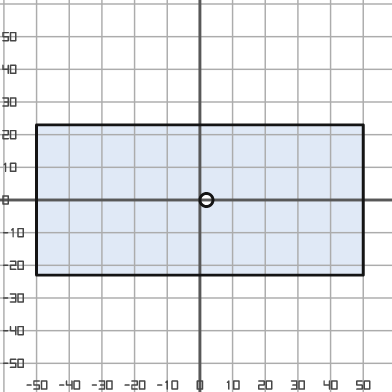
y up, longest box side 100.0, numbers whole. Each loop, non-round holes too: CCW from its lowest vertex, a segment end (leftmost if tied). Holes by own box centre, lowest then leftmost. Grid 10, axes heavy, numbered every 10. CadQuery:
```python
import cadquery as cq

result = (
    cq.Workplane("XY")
    .moveTo(-50.0, -23.0)
    .lineTo(50.0, -23.0)
    .lineTo(50.0, 23.0)
    .lineTo(-50.0, 23.0)
    .close()
    .moveTo(2.0, 0.0)
    .circle(2.0)
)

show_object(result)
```